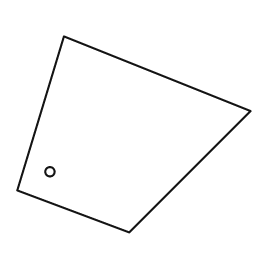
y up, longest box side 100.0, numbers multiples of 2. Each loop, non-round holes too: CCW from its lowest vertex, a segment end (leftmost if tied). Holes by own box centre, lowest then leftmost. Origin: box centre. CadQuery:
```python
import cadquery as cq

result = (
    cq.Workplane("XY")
    .moveTo(-2.0, -42.0)
    .lineTo(50.0, 10.0)
    .lineTo(-30.0, 42.0)
    .lineTo(-50.0, -24.0)
    .close()
    .moveTo(-36.0, -16.0)
    .circle(2.0)
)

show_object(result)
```